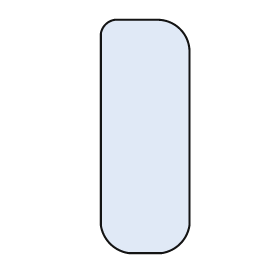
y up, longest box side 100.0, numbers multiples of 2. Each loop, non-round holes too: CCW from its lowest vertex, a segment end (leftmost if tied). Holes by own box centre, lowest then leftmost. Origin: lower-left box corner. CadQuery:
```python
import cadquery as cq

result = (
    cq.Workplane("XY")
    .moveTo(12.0, 0.0)
    .lineTo(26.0, 0.0)
    .threePointArc((34.0, 4.0), (38.0, 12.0))
    .lineTo(38.0, 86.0)
    .threePointArc((34.0, 96.0), (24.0, 100.0))
    .lineTo(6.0, 100.0)
    .threePointArc((2.0, 98.0), (0.0, 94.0))
    .lineTo(0.0, 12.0)
    .threePointArc((4.0, 4.0), (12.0, 0.0))
    .close()
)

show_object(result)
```